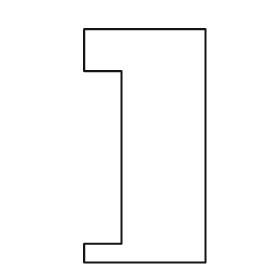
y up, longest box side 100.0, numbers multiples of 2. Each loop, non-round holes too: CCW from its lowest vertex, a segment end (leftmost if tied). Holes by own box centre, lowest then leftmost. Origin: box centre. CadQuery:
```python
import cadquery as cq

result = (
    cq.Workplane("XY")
    .moveTo(-26.0, -50.0)
    .lineTo(26.0, -50.0)
    .lineTo(26.0, 50.0)
    .lineTo(-26.0, 50.0)
    .lineTo(-26.0, 32.0)
    .lineTo(-10.0, 32.0)
    .lineTo(-10.0, -42.0)
    .lineTo(-26.0, -42.0)
    .close()
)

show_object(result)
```